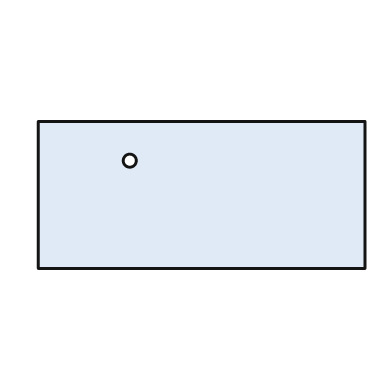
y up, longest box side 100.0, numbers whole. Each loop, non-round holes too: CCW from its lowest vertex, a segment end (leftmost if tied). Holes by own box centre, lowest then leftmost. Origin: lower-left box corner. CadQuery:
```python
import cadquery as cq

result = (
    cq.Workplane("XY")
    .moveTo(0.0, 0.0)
    .lineTo(100.0, 0.0)
    .lineTo(100.0, 45.0)
    .lineTo(0.0, 45.0)
    .close()
    .moveTo(28.0, 33.0)
    .circle(2.0)
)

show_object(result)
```